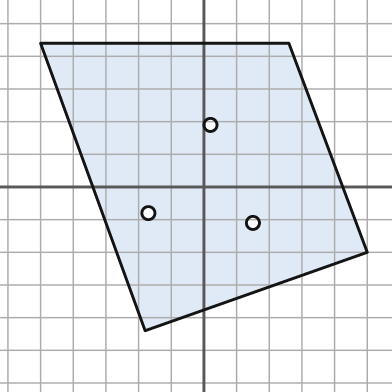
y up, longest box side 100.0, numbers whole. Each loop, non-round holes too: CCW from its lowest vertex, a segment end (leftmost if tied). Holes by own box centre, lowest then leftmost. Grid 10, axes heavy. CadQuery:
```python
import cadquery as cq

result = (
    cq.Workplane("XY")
    .moveTo(-18.0, -44.0)
    .lineTo(50.0, -20.0)
    .lineTo(26.0, 44.0)
    .lineTo(-50.0, 44.0)
    .close()
    .moveTo(15.0, -11.0)
    .circle(2.0)
    .moveTo(-17.0, -8.0)
    .circle(2.0)
    .moveTo(2.0, 19.0)
    .circle(2.0)
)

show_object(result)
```